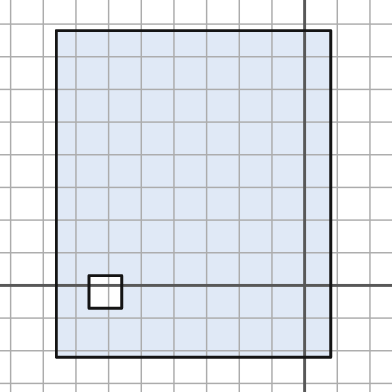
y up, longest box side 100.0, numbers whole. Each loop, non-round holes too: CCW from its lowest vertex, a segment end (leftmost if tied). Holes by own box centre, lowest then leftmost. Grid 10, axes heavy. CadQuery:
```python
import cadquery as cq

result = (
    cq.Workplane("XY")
    .moveTo(-76.0, -22.0)
    .lineTo(8.0, -22.0)
    .lineTo(8.0, 78.0)
    .lineTo(-76.0, 78.0)
    .close()
    .moveTo(-66.0, -7.0)
    .lineTo(-56.0, -7.0)
    .lineTo(-56.0, 3.0)
    .lineTo(-66.0, 3.0)
    .close()
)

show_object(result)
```